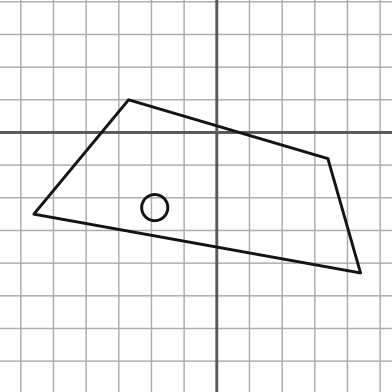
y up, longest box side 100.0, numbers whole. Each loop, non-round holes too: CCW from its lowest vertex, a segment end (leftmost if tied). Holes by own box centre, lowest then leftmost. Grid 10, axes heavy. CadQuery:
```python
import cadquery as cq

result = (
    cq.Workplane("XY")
    .moveTo(44.0, -43.0)
    .lineTo(34.0, -8.0)
    .lineTo(-27.0, 10.0)
    .lineTo(-56.0, -25.0)
    .close()
    .moveTo(-19.0, -23.0)
    .circle(4.0)
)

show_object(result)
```